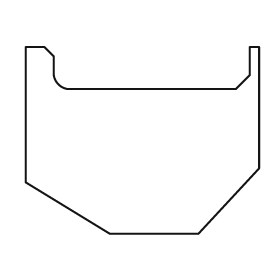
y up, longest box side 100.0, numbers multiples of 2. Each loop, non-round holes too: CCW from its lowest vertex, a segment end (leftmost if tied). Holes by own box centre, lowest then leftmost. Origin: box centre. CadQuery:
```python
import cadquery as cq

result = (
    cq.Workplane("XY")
    .moveTo(-14.0, -40.0)
    .lineTo(24.0, -40.0)
    .lineTo(50.0, -12.0)
    .lineTo(50.0, 40.0)
    .lineTo(46.0, 40.0)
    .lineTo(46.0, 28.0)
    .lineTo(40.0, 22.0)
    .lineTo(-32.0, 22.0)
    .threePointArc((-36.0, 24.0), (-38.0, 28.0))
    .lineTo(-38.0, 36.0)
    .lineTo(-42.0, 40.0)
    .lineTo(-50.0, 40.0)
    .lineTo(-50.0, -18.0)
    .close()
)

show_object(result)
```